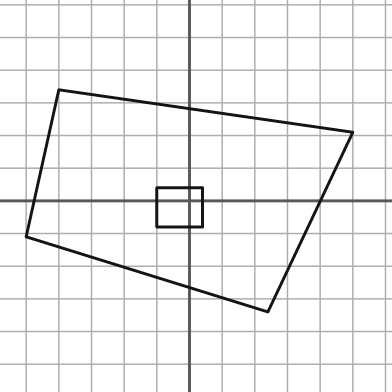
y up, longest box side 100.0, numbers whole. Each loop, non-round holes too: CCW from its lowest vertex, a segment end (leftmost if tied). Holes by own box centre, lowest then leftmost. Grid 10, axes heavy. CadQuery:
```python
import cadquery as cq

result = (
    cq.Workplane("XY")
    .moveTo(24.0, -34.0)
    .lineTo(50.0, 21.0)
    .lineTo(-40.0, 34.0)
    .lineTo(-50.0, -11.0)
    .close()
    .moveTo(-10.0, -8.0)
    .lineTo(4.0, -8.0)
    .lineTo(4.0, 4.0)
    .lineTo(-10.0, 4.0)
    .close()
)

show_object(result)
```